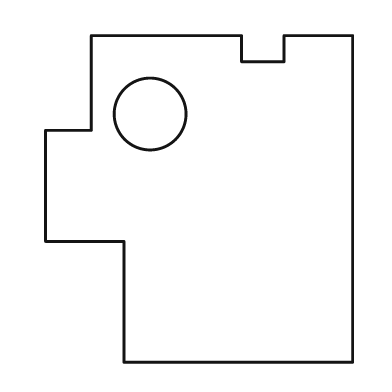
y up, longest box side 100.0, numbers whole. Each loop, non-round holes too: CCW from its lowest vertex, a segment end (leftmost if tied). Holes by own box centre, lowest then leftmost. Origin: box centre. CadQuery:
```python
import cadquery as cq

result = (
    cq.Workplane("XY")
    .moveTo(-23.0, -50.0)
    .lineTo(47.0, -50.0)
    .lineTo(47.0, 50.0)
    .lineTo(26.0, 50.0)
    .lineTo(26.0, 42.0)
    .lineTo(13.0, 42.0)
    .lineTo(13.0, 50.0)
    .lineTo(-33.0, 50.0)
    .lineTo(-33.0, 21.0)
    .lineTo(-47.0, 21.0)
    .lineTo(-47.0, -13.0)
    .lineTo(-23.0, -13.0)
    .close()
    .moveTo(-15.0, 26.0)
    .circle(11.0)
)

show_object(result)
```